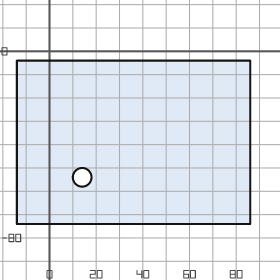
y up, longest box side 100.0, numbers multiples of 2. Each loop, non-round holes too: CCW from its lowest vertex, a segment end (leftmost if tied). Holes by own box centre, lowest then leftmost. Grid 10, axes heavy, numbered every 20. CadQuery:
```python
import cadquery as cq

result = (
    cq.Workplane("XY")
    .moveTo(-14.0, -74.0)
    .lineTo(86.0, -74.0)
    .lineTo(86.0, -4.0)
    .lineTo(-14.0, -4.0)
    .close()
    .moveTo(14.0, -54.0)
    .circle(4.0)
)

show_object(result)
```